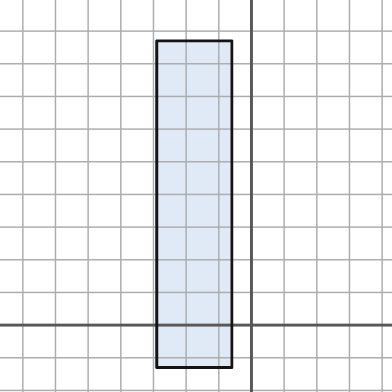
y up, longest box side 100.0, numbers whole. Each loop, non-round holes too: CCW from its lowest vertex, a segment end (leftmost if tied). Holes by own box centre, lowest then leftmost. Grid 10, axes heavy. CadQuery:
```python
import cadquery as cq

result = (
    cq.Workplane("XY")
    .moveTo(-29.0, -13.0)
    .lineTo(-6.0, -13.0)
    .lineTo(-6.0, 87.0)
    .lineTo(-29.0, 87.0)
    .close()
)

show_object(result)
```